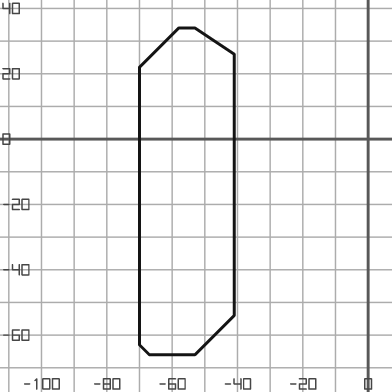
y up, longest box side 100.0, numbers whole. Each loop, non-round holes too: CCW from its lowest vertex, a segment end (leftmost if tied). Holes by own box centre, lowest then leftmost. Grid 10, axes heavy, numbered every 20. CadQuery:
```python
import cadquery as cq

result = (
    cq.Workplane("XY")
    .moveTo(-67.0, -66.0)
    .lineTo(-53.0, -66.0)
    .lineTo(-41.0, -54.0)
    .lineTo(-41.0, 26.0)
    .lineTo(-53.0, 34.0)
    .lineTo(-58.0, 34.0)
    .lineTo(-70.0, 22.0)
    .lineTo(-70.0, -63.0)
    .close()
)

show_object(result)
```